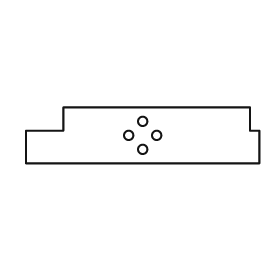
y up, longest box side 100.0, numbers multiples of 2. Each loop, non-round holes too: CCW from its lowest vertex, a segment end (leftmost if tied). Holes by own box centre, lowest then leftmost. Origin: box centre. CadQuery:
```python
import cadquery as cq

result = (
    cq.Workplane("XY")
    .moveTo(-50.0, -12.0)
    .lineTo(50.0, -12.0)
    .lineTo(50.0, 2.0)
    .lineTo(46.0, 2.0)
    .lineTo(46.0, 12.0)
    .lineTo(-34.0, 12.0)
    .lineTo(-34.0, 2.0)
    .lineTo(-50.0, 2.0)
    .close()
    .moveTo(0.0, -6.0)
    .circle(2.0)
    .moveTo(-6.0, 0.0)
    .circle(2.0)
    .moveTo(6.0, 0.0)
    .circle(2.0)
    .moveTo(0.0, 6.0)
    .circle(2.0)
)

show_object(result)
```